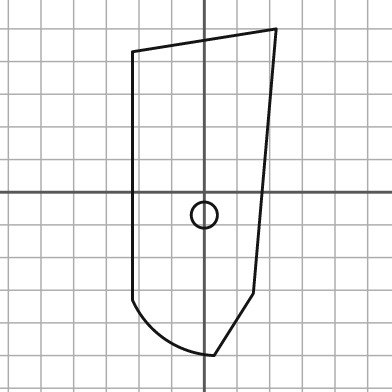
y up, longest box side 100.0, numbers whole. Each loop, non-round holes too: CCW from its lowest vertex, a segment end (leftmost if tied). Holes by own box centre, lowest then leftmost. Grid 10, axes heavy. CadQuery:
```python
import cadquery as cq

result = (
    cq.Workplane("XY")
    .moveTo(3.0, -50.0)
    .lineTo(15.0, -31.0)
    .lineTo(22.0, 50.0)
    .lineTo(-22.0, 43.0)
    .lineTo(-22.0, -33.0)
    .threePointArc((-12.0, -45.0), (3.0, -50.0))
    .close()
    .moveTo(0.0, -7.0)
    .circle(4.0)
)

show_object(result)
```